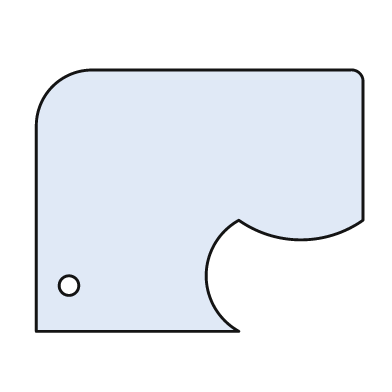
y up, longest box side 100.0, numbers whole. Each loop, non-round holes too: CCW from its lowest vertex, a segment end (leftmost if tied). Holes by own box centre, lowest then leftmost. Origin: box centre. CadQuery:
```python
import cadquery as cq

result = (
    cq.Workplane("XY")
    .moveTo(-50.0, -40.0)
    .lineTo(12.0, -40.0)
    .threePointArc((2.0, -23.0), (12.0, -6.0))
    .threePointArc((31.0, -12.0), (50.0, -6.0))
    .lineTo(50.0, 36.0)
    .threePointArc((49.0, 39.0), (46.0, 40.0))
    .lineTo(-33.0, 40.0)
    .threePointArc((-45.0, 35.0), (-50.0, 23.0))
    .close()
    .moveTo(-40.0, -26.0)
    .circle(3.0)
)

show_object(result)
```